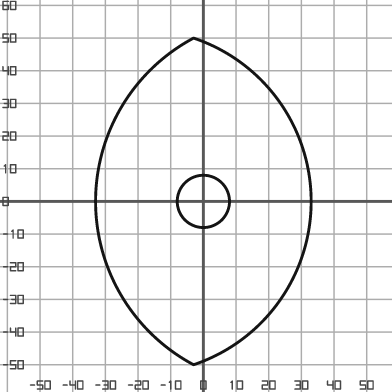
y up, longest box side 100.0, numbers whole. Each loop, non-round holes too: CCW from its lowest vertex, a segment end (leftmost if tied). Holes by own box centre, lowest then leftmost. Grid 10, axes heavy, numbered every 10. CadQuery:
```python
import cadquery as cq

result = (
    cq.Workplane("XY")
    .moveTo(-3.0, -50.0)
    .threePointArc((33.0, 0.0), (-3.0, 50.0))
    .threePointArc((-33.0, 0.0), (-3.0, -50.0))
    .close()
    .moveTo(0.0, 0.0)
    .circle(8.0)
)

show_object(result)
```